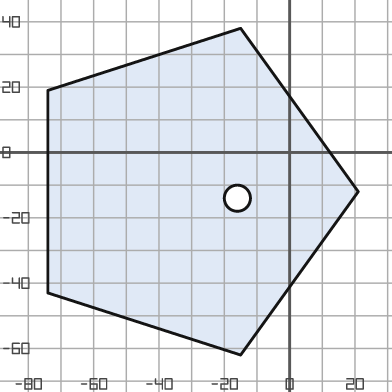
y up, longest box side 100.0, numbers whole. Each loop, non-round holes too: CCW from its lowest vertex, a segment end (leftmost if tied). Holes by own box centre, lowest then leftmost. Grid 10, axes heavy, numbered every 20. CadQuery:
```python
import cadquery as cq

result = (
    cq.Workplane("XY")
    .moveTo(-15.0, -62.0)
    .lineTo(21.0, -12.0)
    .lineTo(-15.0, 38.0)
    .lineTo(-74.0, 19.0)
    .lineTo(-74.0, -43.0)
    .close()
    .moveTo(-16.0, -14.0)
    .circle(4.0)
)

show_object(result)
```